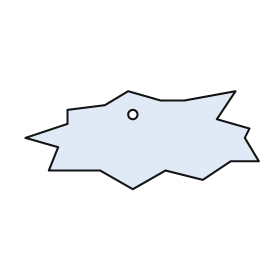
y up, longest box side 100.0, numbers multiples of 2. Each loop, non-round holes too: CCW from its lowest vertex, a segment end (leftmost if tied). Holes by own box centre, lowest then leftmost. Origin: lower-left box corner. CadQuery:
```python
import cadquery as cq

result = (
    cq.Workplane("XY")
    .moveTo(46.0, 0.0)
    .lineTo(60.0, 8.0)
    .lineTo(76.0, 4.0)
    .lineTo(88.0, 12.0)
    .lineTo(100.0, 12.0)
    .lineTo(94.0, 22.0)
    .lineTo(96.0, 26.0)
    .lineTo(82.0, 30.0)
    .lineTo(90.0, 42.0)
    .lineTo(68.0, 38.0)
    .lineTo(58.0, 38.0)
    .lineTo(44.0, 42.0)
    .lineTo(34.0, 36.0)
    .lineTo(18.0, 34.0)
    .lineTo(18.0, 28.0)
    .lineTo(0.0, 22.0)
    .lineTo(14.0, 18.0)
    .lineTo(10.0, 8.0)
    .lineTo(32.0, 8.0)
    .close()
    .moveTo(46.0, 32.0)
    .circle(2.0)
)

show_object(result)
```